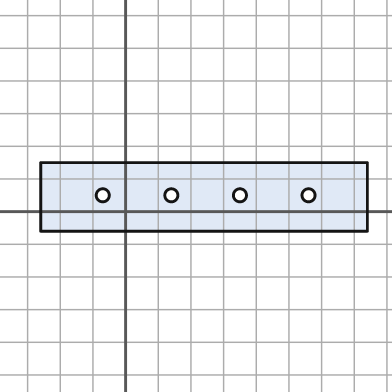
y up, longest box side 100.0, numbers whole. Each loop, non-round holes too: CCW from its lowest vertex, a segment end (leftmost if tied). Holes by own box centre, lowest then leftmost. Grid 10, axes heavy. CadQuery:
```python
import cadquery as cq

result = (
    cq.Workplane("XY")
    .moveTo(-26.0, -6.0)
    .lineTo(74.0, -6.0)
    .lineTo(74.0, 15.0)
    .lineTo(-26.0, 15.0)
    .close()
    .moveTo(-7.0, 5.0)
    .circle(2.0)
    .moveTo(14.0, 5.0)
    .circle(2.0)
    .moveTo(35.0, 5.0)
    .circle(2.0)
    .moveTo(56.0, 5.0)
    .circle(2.0)
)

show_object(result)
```